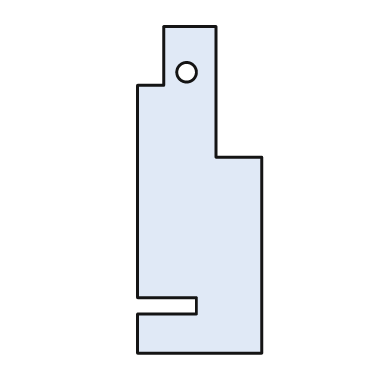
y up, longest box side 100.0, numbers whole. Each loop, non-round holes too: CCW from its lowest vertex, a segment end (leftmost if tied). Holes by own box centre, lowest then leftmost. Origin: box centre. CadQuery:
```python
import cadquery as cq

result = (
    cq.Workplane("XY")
    .moveTo(-19.0, -50.0)
    .lineTo(19.0, -50.0)
    .lineTo(19.0, 10.0)
    .lineTo(5.0, 10.0)
    .lineTo(5.0, 50.0)
    .lineTo(-11.0, 50.0)
    .lineTo(-11.0, 32.0)
    .lineTo(-19.0, 32.0)
    .lineTo(-19.0, -33.0)
    .lineTo(-1.0, -33.0)
    .lineTo(-1.0, -38.0)
    .lineTo(-19.0, -38.0)
    .close()
    .moveTo(-4.0, 36.0)
    .circle(3.0)
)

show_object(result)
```